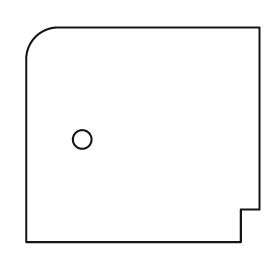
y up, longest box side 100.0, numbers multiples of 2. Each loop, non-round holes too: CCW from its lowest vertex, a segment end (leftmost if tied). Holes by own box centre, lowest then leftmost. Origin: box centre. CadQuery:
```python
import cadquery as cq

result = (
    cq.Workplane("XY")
    .moveTo(-50.0, -46.0)
    .lineTo(42.0, -46.0)
    .lineTo(42.0, -32.0)
    .lineTo(50.0, -32.0)
    .lineTo(50.0, 46.0)
    .lineTo(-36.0, 46.0)
    .threePointArc((-46.0, 42.0), (-50.0, 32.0))
    .close()
    .moveTo(-26.0, -2.0)
    .circle(4.0)
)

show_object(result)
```